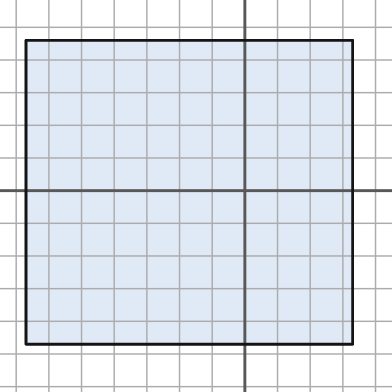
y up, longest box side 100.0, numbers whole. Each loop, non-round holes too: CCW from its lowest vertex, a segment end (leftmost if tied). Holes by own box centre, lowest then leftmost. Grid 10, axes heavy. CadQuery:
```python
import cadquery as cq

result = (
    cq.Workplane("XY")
    .moveTo(-67.0, -47.0)
    .lineTo(33.0, -47.0)
    .lineTo(33.0, 46.0)
    .lineTo(-67.0, 46.0)
    .close()
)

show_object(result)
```